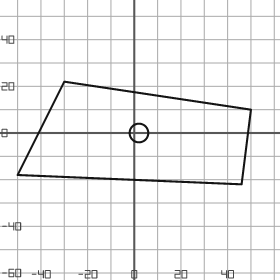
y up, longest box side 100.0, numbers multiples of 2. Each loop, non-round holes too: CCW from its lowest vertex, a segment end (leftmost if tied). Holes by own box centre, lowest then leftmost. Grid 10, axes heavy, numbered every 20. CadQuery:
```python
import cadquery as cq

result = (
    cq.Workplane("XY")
    .moveTo(46.0, -22.0)
    .lineTo(50.0, 10.0)
    .lineTo(-30.0, 22.0)
    .lineTo(-50.0, -18.0)
    .close()
    .moveTo(2.0, 0.0)
    .circle(4.0)
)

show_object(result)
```